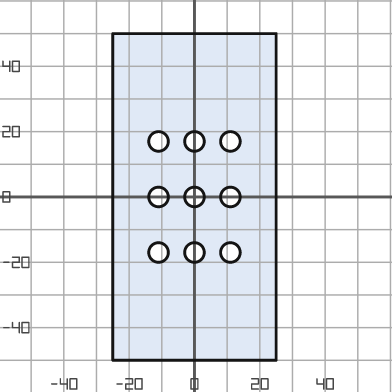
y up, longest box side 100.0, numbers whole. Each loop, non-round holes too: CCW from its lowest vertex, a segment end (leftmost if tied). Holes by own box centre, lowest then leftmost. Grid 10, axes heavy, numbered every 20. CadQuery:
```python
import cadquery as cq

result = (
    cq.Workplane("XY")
    .moveTo(-25.0, -50.0)
    .lineTo(25.0, -50.0)
    .lineTo(25.0, 50.0)
    .lineTo(-25.0, 50.0)
    .close()
    .moveTo(-11.0, -17.0)
    .circle(3.0)
    .moveTo(0.0, -17.0)
    .circle(3.0)
    .moveTo(11.0, -17.0)
    .circle(3.0)
    .moveTo(-11.0, 0.0)
    .circle(3.0)
    .moveTo(0.0, 0.0)
    .circle(3.0)
    .moveTo(11.0, 0.0)
    .circle(3.0)
    .moveTo(-11.0, 17.0)
    .circle(3.0)
    .moveTo(0.0, 17.0)
    .circle(3.0)
    .moveTo(11.0, 17.0)
    .circle(3.0)
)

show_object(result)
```